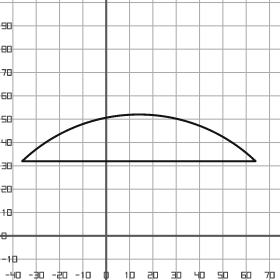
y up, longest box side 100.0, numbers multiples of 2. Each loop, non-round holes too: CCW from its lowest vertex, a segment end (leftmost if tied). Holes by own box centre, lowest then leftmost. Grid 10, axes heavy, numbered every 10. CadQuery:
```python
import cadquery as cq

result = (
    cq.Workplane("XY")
    .moveTo(-36.0, 32.0)
    .lineTo(64.0, 32.0)
    .threePointArc((14.0, 52.0), (-36.0, 32.0))
    .close()
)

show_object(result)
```